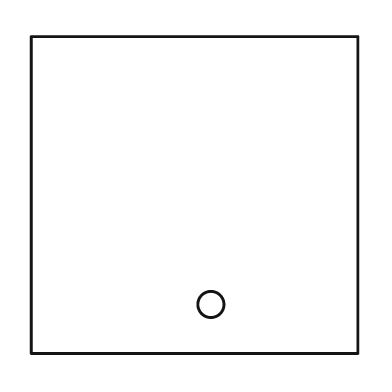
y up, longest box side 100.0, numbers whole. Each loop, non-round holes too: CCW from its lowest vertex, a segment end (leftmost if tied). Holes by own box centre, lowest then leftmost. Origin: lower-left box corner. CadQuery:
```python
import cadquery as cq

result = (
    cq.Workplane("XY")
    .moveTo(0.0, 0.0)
    .lineTo(100.0, 0.0)
    .lineTo(100.0, 97.0)
    .lineTo(0.0, 97.0)
    .close()
    .moveTo(55.0, 15.0)
    .circle(4.0)
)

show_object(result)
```